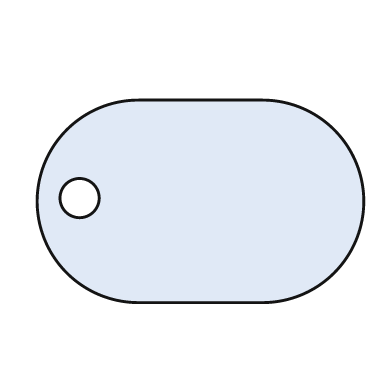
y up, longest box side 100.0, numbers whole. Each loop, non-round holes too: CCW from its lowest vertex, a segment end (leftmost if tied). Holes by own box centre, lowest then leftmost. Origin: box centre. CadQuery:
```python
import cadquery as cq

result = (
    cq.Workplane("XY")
    .moveTo(-19.0, -31.0)
    .lineTo(19.0, -31.0)
    .threePointArc((50.0, 0.0), (19.0, 31.0))
    .lineTo(-19.0, 31.0)
    .threePointArc((-50.0, 0.0), (-19.0, -31.0))
    .close()
    .moveTo(-37.0, 1.0)
    .circle(6.0)
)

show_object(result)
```